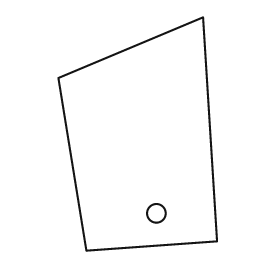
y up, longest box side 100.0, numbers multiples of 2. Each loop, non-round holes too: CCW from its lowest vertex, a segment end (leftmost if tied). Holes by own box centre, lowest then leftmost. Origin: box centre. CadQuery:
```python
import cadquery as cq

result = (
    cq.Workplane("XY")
    .moveTo(-22.0, -50.0)
    .lineTo(34.0, -46.0)
    .lineTo(28.0, 50.0)
    .lineTo(-34.0, 24.0)
    .close()
    .moveTo(8.0, -34.0)
    .circle(4.0)
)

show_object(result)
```